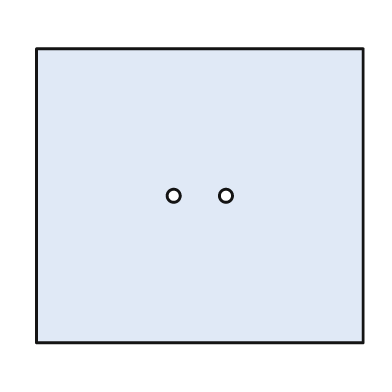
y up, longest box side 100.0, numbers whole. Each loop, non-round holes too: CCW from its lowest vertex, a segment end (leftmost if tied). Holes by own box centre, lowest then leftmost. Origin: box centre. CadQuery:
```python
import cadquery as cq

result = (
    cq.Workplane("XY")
    .moveTo(-50.0, -45.0)
    .lineTo(50.0, -45.0)
    .lineTo(50.0, 45.0)
    .lineTo(-50.0, 45.0)
    .close()
    .moveTo(-8.0, 0.0)
    .circle(2.0)
    .moveTo(8.0, 0.0)
    .circle(2.0)
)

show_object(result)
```